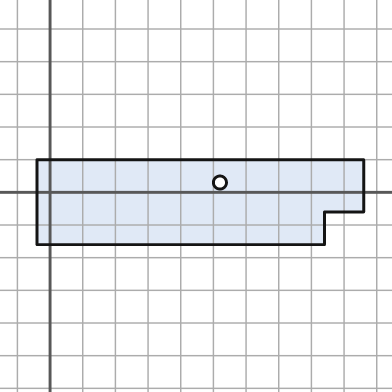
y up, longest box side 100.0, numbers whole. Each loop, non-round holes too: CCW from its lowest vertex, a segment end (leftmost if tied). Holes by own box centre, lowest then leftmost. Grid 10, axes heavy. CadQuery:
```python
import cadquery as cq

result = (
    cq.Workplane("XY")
    .moveTo(-4.0, -16.0)
    .lineTo(84.0, -16.0)
    .lineTo(84.0, -6.0)
    .lineTo(96.0, -6.0)
    .lineTo(96.0, 10.0)
    .lineTo(-4.0, 10.0)
    .close()
    .moveTo(52.0, 3.0)
    .circle(2.0)
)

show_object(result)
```